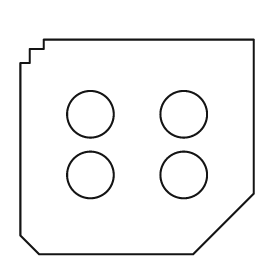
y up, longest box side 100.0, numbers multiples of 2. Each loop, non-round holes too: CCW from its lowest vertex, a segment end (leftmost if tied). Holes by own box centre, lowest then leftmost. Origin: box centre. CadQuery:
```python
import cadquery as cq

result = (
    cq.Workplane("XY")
    .moveTo(-42.0, -46.0)
    .lineTo(24.0, -46.0)
    .lineTo(50.0, -20.0)
    .lineTo(50.0, 46.0)
    .lineTo(-40.0, 46.0)
    .lineTo(-40.0, 42.0)
    .lineTo(-46.0, 42.0)
    .lineTo(-46.0, 36.0)
    .lineTo(-50.0, 36.0)
    .lineTo(-50.0, -38.0)
    .close()
    .moveTo(-20.0, -12.0)
    .circle(10.0)
    .moveTo(20.0, -12.0)
    .circle(10.0)
    .moveTo(-20.0, 14.0)
    .circle(10.0)
    .moveTo(20.0, 14.0)
    .circle(10.0)
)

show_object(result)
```